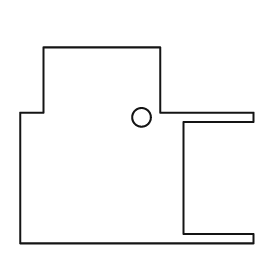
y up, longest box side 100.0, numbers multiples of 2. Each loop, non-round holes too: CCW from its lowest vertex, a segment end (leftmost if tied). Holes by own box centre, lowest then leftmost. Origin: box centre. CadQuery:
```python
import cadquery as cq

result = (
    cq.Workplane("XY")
    .moveTo(-50.0, -42.0)
    .lineTo(50.0, -42.0)
    .lineTo(50.0, -38.0)
    .lineTo(20.0, -38.0)
    .lineTo(20.0, 10.0)
    .lineTo(50.0, 10.0)
    .lineTo(50.0, 14.0)
    .lineTo(10.0, 14.0)
    .lineTo(10.0, 42.0)
    .lineTo(-40.0, 42.0)
    .lineTo(-40.0, 14.0)
    .lineTo(-50.0, 14.0)
    .close()
    .moveTo(2.0, 12.0)
    .circle(4.0)
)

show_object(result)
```